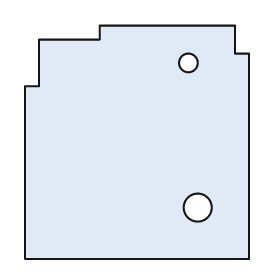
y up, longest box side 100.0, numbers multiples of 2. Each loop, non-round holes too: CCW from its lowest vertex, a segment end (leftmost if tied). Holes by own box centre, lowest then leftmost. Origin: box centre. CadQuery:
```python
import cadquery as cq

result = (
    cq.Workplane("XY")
    .moveTo(-48.0, -50.0)
    .lineTo(48.0, -50.0)
    .lineTo(48.0, 38.0)
    .lineTo(42.0, 38.0)
    .lineTo(42.0, 50.0)
    .lineTo(-16.0, 50.0)
    .lineTo(-16.0, 44.0)
    .lineTo(-42.0, 44.0)
    .lineTo(-42.0, 24.0)
    .lineTo(-48.0, 24.0)
    .close()
    .moveTo(26.0, -28.0)
    .circle(6.0)
    .moveTo(22.0, 34.0)
    .circle(4.0)
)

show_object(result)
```